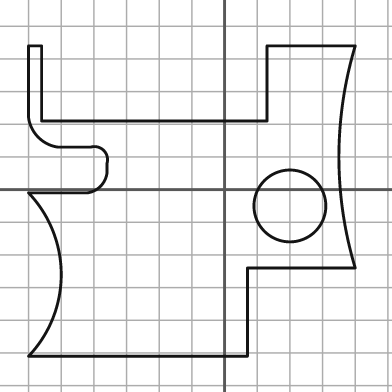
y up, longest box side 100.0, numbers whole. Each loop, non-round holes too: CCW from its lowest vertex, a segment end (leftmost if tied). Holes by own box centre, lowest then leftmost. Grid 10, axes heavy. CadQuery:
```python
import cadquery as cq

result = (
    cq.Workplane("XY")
    .moveTo(-60.0, -51.0)
    .lineTo(7.0, -51.0)
    .lineTo(7.0, -24.0)
    .lineTo(40.0, -24.0)
    .threePointArc((35.0, 10.0), (40.0, 44.0))
    .lineTo(13.0, 44.0)
    .lineTo(13.0, 21.0)
    .lineTo(-56.0, 21.0)
    .lineTo(-56.0, 44.0)
    .lineTo(-60.0, 44.0)
    .lineTo(-60.0, 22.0)
    .threePointArc((-57.0, 16.0), (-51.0, 13.0))
    .lineTo(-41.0, 13.0)
    .threePointArc((-37.0, 12.0), (-36.0, 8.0))
    .lineTo(-36.0, 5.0)
    .threePointArc((-38.0, 1.0), (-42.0, -1.0))
    .lineTo(-60.0, -1.0)
    .threePointArc((-50.0, -26.0), (-60.0, -51.0))
    .close()
    .moveTo(20.0, -5.0)
    .circle(11.0)
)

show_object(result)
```